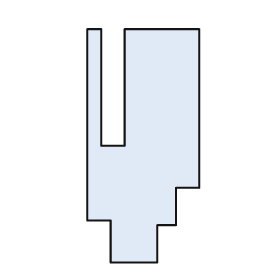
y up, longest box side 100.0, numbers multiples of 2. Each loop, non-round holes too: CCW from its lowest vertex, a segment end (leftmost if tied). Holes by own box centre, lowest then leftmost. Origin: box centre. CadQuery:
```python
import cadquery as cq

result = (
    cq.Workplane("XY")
    .moveTo(-14.0, -50.0)
    .lineTo(6.0, -50.0)
    .lineTo(6.0, -34.0)
    .lineTo(14.0, -34.0)
    .lineTo(14.0, -18.0)
    .lineTo(24.0, -18.0)
    .lineTo(24.0, 50.0)
    .lineTo(-8.0, 50.0)
    .lineTo(-8.0, 0.0)
    .lineTo(-18.0, 0.0)
    .lineTo(-18.0, 50.0)
    .lineTo(-24.0, 50.0)
    .lineTo(-24.0, -32.0)
    .lineTo(-14.0, -32.0)
    .close()
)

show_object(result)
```